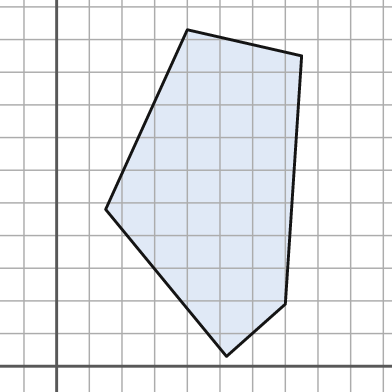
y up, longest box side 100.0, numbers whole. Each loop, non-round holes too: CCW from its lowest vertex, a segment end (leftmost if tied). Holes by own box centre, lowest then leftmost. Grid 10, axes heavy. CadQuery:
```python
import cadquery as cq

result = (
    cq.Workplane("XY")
    .moveTo(52.0, 3.0)
    .lineTo(70.0, 19.0)
    .lineTo(75.0, 95.0)
    .lineTo(40.0, 103.0)
    .lineTo(15.0, 48.0)
    .close()
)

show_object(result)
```